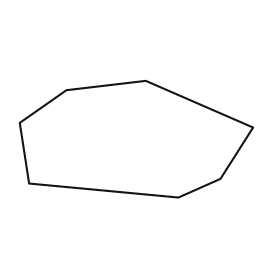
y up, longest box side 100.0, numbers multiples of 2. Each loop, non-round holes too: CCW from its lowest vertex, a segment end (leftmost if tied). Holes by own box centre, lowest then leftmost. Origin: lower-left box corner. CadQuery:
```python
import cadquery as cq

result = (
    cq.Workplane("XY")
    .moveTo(68.0, 0.0)
    .lineTo(86.0, 8.0)
    .lineTo(100.0, 30.0)
    .lineTo(54.0, 50.0)
    .lineTo(20.0, 46.0)
    .lineTo(0.0, 32.0)
    .lineTo(4.0, 6.0)
    .close()
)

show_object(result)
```